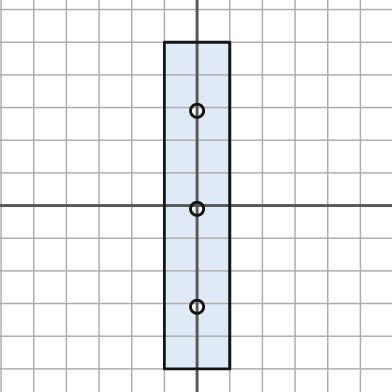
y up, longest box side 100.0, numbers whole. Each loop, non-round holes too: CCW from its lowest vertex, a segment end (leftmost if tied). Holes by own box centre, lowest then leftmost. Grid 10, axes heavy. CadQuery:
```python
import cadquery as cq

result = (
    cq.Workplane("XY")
    .moveTo(-10.0, -50.0)
    .lineTo(10.0, -50.0)
    .lineTo(10.0, 50.0)
    .lineTo(-10.0, 50.0)
    .close()
    .moveTo(0.0, -31.0)
    .circle(2.0)
    .moveTo(0.0, -1.0)
    .circle(2.0)
    .moveTo(0.0, 29.0)
    .circle(2.0)
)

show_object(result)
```